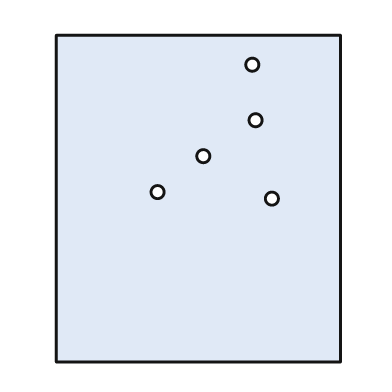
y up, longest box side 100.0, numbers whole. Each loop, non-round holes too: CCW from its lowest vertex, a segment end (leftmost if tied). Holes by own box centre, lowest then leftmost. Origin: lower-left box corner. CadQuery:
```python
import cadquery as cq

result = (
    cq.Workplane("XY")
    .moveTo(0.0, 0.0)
    .lineTo(87.0, 0.0)
    .lineTo(87.0, 100.0)
    .lineTo(0.0, 100.0)
    .close()
    .moveTo(66.0, 50.0)
    .circle(2.0)
    .moveTo(31.0, 52.0)
    .circle(2.0)
    .moveTo(45.0, 63.0)
    .circle(2.0)
    .moveTo(61.0, 74.0)
    .circle(2.0)
    .moveTo(60.0, 91.0)
    .circle(2.0)
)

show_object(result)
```